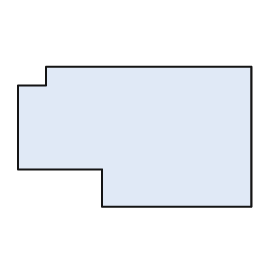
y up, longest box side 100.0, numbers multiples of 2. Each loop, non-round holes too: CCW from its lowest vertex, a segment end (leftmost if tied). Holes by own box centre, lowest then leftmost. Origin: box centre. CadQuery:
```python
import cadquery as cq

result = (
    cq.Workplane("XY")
    .moveTo(-14.0, -30.0)
    .lineTo(50.0, -30.0)
    .lineTo(50.0, 30.0)
    .lineTo(-38.0, 30.0)
    .lineTo(-38.0, 22.0)
    .lineTo(-50.0, 22.0)
    .lineTo(-50.0, -14.0)
    .lineTo(-14.0, -14.0)
    .close()
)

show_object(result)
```